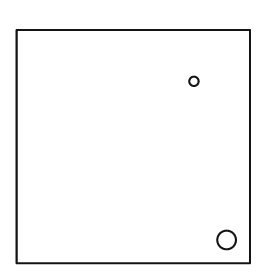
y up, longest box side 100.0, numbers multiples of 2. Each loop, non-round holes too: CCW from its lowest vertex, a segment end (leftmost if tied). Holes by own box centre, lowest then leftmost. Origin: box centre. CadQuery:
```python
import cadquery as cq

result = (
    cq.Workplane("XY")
    .moveTo(-50.0, -50.0)
    .lineTo(50.0, -50.0)
    .lineTo(50.0, 50.0)
    .lineTo(-50.0, 50.0)
    .close()
    .moveTo(40.0, -40.0)
    .circle(4.0)
    .moveTo(26.0, 28.0)
    .circle(2.0)
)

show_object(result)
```